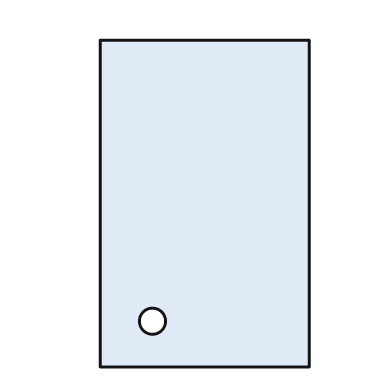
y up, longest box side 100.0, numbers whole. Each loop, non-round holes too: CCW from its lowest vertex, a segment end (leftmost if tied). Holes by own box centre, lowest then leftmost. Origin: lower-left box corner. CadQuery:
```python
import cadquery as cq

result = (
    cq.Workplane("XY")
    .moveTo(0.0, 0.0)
    .lineTo(64.0, 0.0)
    .lineTo(64.0, 100.0)
    .lineTo(0.0, 100.0)
    .close()
    .moveTo(16.0, 14.0)
    .circle(4.0)
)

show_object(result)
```